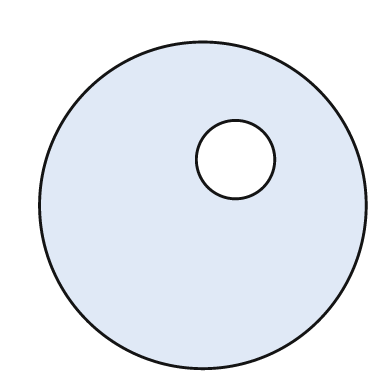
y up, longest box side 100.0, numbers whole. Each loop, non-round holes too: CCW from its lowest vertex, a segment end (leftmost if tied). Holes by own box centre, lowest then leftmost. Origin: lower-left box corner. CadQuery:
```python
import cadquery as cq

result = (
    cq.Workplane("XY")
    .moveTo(50.0, 50.0)
    .circle(50.0)
    .moveTo(60.0, 64.0)
    .circle(12.0)
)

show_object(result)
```